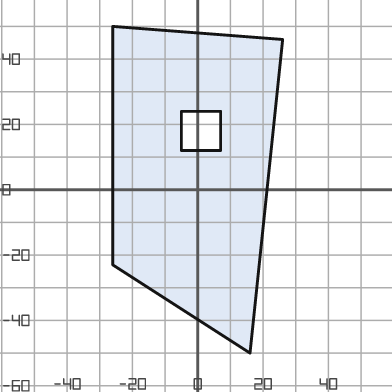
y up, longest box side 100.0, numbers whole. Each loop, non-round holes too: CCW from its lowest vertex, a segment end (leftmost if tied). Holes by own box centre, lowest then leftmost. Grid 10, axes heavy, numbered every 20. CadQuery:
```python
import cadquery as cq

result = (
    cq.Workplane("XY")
    .moveTo(16.0, -50.0)
    .lineTo(26.0, 46.0)
    .lineTo(-26.0, 50.0)
    .lineTo(-26.0, -23.0)
    .close()
    .moveTo(-5.0, 12.0)
    .lineTo(7.0, 12.0)
    .lineTo(7.0, 24.0)
    .lineTo(-5.0, 24.0)
    .close()
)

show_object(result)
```